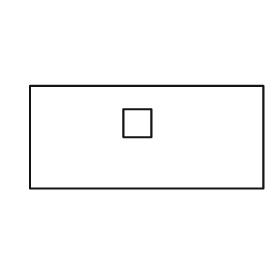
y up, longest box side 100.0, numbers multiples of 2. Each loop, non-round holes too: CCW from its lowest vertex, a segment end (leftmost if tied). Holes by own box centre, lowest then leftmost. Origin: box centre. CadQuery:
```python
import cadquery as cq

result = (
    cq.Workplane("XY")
    .moveTo(-50.0, -22.0)
    .lineTo(50.0, -22.0)
    .lineTo(50.0, 22.0)
    .lineTo(-50.0, 22.0)
    .close()
    .moveTo(-10.0, 0.0)
    .lineTo(2.0, 0.0)
    .lineTo(2.0, 12.0)
    .lineTo(-10.0, 12.0)
    .close()
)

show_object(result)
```